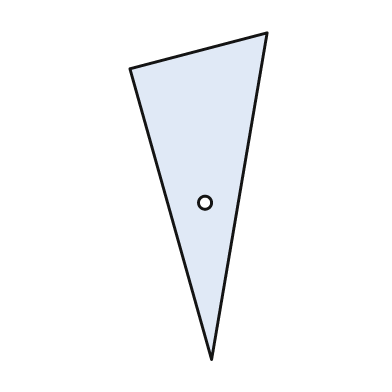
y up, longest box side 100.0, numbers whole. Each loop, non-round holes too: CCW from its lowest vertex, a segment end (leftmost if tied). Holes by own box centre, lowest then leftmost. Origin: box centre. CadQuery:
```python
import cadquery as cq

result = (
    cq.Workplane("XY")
    .moveTo(4.0, -50.0)
    .lineTo(21.0, 50.0)
    .lineTo(-21.0, 39.0)
    .close()
    .moveTo(2.0, -2.0)
    .circle(2.0)
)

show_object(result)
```